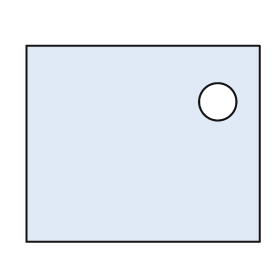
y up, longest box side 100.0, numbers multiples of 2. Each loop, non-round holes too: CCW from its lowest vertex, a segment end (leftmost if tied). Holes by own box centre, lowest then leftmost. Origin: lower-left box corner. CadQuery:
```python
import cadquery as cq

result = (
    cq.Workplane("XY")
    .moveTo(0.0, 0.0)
    .lineTo(100.0, 0.0)
    .lineTo(100.0, 84.0)
    .lineTo(0.0, 84.0)
    .close()
    .moveTo(82.0, 60.0)
    .circle(8.0)
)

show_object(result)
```